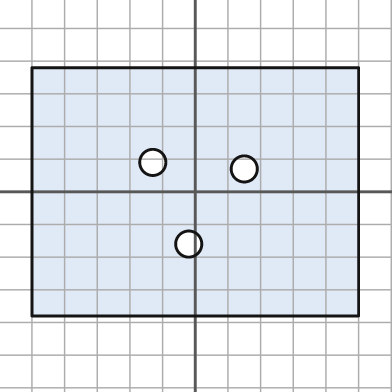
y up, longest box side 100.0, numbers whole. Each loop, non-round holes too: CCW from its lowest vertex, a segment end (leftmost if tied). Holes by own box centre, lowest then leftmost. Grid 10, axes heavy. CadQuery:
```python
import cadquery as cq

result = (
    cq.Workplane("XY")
    .moveTo(-50.0, -38.0)
    .lineTo(50.0, -38.0)
    .lineTo(50.0, 38.0)
    .lineTo(-50.0, 38.0)
    .close()
    .moveTo(-2.0, -16.0)
    .circle(4.0)
    .moveTo(15.0, 7.0)
    .circle(4.0)
    .moveTo(-13.0, 9.0)
    .circle(4.0)
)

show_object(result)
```